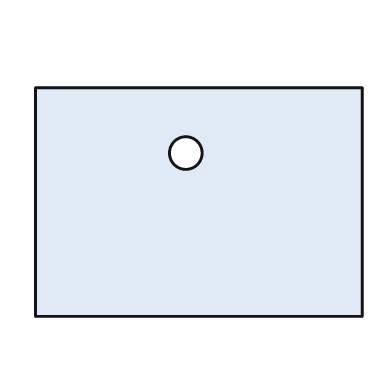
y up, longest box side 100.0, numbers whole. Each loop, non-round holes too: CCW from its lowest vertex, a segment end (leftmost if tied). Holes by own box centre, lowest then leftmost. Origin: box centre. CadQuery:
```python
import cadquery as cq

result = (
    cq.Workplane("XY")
    .moveTo(-50.0, -35.0)
    .lineTo(50.0, -35.0)
    .lineTo(50.0, 35.0)
    .lineTo(-50.0, 35.0)
    .close()
    .moveTo(-4.0, 15.0)
    .circle(5.0)
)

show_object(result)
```